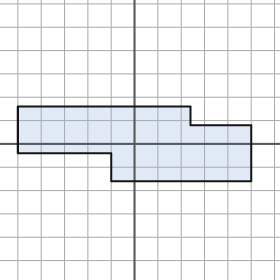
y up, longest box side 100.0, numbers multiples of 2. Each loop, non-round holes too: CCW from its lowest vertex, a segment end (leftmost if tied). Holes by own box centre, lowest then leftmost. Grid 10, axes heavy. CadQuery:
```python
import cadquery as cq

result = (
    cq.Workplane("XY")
    .moveTo(-10.0, -16.0)
    .lineTo(50.0, -16.0)
    .lineTo(50.0, 8.0)
    .lineTo(24.0, 8.0)
    .lineTo(24.0, 16.0)
    .lineTo(-50.0, 16.0)
    .lineTo(-50.0, -4.0)
    .lineTo(-10.0, -4.0)
    .close()
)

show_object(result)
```